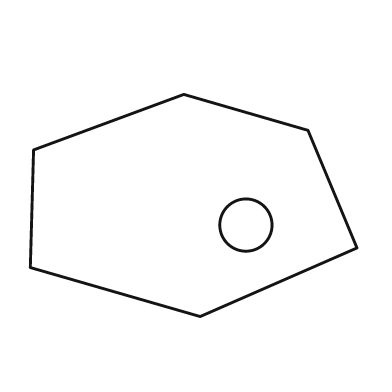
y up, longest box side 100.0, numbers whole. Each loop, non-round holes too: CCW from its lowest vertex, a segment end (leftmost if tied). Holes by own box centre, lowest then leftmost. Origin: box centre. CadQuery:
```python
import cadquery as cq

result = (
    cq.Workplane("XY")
    .moveTo(2.0, -34.0)
    .lineTo(50.0, -13.0)
    .lineTo(35.0, 23.0)
    .lineTo(-3.0, 34.0)
    .lineTo(-49.0, 17.0)
    .lineTo(-50.0, -19.0)
    .close()
    .moveTo(16.0, -6.0)
    .circle(8.0)
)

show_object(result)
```